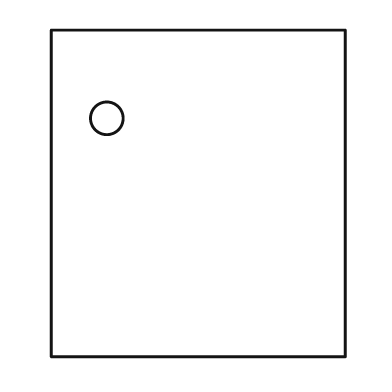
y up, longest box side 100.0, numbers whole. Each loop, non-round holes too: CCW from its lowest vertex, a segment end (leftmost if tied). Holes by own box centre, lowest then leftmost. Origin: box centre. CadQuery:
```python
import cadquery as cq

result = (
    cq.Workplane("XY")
    .moveTo(-45.0, -50.0)
    .lineTo(45.0, -50.0)
    .lineTo(45.0, 50.0)
    .lineTo(-45.0, 50.0)
    .close()
    .moveTo(-28.0, 23.0)
    .circle(5.0)
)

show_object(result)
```